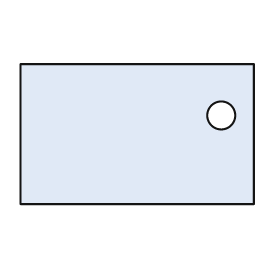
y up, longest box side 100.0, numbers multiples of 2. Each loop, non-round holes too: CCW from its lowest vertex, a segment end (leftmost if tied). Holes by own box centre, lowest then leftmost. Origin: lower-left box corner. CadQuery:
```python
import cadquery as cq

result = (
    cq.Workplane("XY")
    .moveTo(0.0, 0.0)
    .lineTo(100.0, 0.0)
    .lineTo(100.0, 60.0)
    .lineTo(0.0, 60.0)
    .close()
    .moveTo(86.0, 38.0)
    .circle(6.0)
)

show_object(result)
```